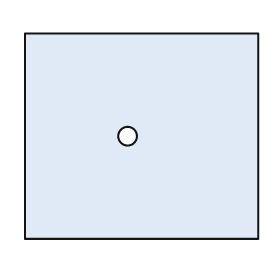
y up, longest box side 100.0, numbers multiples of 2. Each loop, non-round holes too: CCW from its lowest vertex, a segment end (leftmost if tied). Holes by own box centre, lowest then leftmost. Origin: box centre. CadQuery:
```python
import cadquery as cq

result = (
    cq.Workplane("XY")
    .moveTo(-50.0, -44.0)
    .lineTo(50.0, -44.0)
    .lineTo(50.0, 44.0)
    .lineTo(-50.0, 44.0)
    .close()
    .moveTo(-6.0, 0.0)
    .circle(4.0)
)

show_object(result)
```